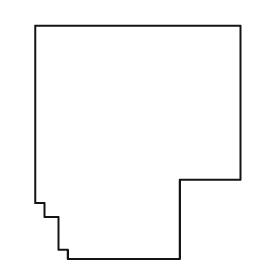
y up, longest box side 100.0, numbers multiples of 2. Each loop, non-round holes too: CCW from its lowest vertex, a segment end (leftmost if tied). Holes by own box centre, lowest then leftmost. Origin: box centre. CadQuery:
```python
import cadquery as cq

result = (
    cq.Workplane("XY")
    .moveTo(-30.0, -50.0)
    .lineTo(18.0, -50.0)
    .lineTo(18.0, -16.0)
    .lineTo(44.0, -16.0)
    .lineTo(44.0, 50.0)
    .lineTo(-44.0, 50.0)
    .lineTo(-44.0, -26.0)
    .lineTo(-40.0, -26.0)
    .lineTo(-40.0, -32.0)
    .lineTo(-34.0, -32.0)
    .lineTo(-34.0, -46.0)
    .lineTo(-30.0, -46.0)
    .close()
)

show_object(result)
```